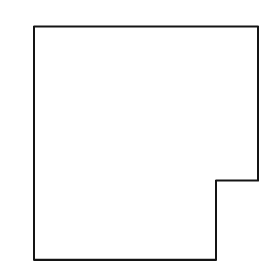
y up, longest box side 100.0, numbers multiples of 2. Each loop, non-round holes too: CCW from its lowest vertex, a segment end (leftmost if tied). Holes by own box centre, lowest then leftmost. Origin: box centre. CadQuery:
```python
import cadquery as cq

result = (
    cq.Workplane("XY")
    .moveTo(-48.0, -50.0)
    .lineTo(30.0, -50.0)
    .lineTo(30.0, -16.0)
    .lineTo(48.0, -16.0)
    .lineTo(48.0, 50.0)
    .lineTo(-48.0, 50.0)
    .close()
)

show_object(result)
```